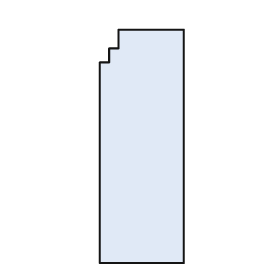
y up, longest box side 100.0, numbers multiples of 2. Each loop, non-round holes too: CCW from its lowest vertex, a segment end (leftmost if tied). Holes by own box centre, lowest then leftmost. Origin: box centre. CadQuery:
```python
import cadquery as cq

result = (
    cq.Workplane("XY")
    .moveTo(-18.0, -50.0)
    .lineTo(18.0, -50.0)
    .lineTo(18.0, 50.0)
    .lineTo(-10.0, 50.0)
    .lineTo(-10.0, 42.0)
    .lineTo(-14.0, 42.0)
    .lineTo(-14.0, 36.0)
    .lineTo(-18.0, 36.0)
    .close()
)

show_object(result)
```